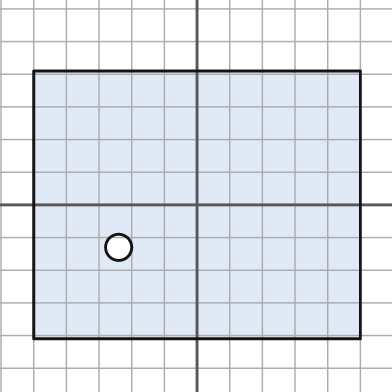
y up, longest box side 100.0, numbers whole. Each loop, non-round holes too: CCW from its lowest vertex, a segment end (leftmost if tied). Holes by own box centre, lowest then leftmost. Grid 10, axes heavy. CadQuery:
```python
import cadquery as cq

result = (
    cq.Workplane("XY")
    .moveTo(-50.0, -41.0)
    .lineTo(50.0, -41.0)
    .lineTo(50.0, 41.0)
    .lineTo(-50.0, 41.0)
    .close()
    .moveTo(-24.0, -13.0)
    .circle(4.0)
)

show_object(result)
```